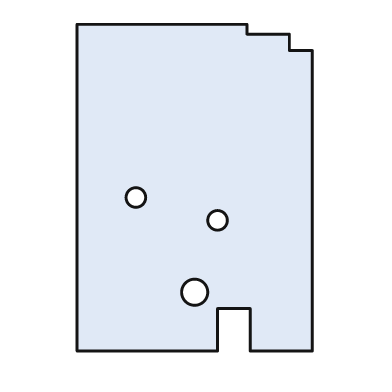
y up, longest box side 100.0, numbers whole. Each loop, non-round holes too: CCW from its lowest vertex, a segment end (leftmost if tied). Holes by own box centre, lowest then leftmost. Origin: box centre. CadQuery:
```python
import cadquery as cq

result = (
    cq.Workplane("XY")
    .moveTo(-36.0, -50.0)
    .lineTo(7.0, -50.0)
    .lineTo(7.0, -37.0)
    .lineTo(17.0, -37.0)
    .lineTo(17.0, -50.0)
    .lineTo(36.0, -50.0)
    .lineTo(36.0, 42.0)
    .lineTo(29.0, 42.0)
    .lineTo(29.0, 47.0)
    .lineTo(16.0, 47.0)
    .lineTo(16.0, 50.0)
    .lineTo(-36.0, 50.0)
    .close()
    .moveTo(0.0, -32.0)
    .circle(4.0)
    .moveTo(7.0, -10.0)
    .circle(3.0)
    .moveTo(-18.0, -3.0)
    .circle(3.0)
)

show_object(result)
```